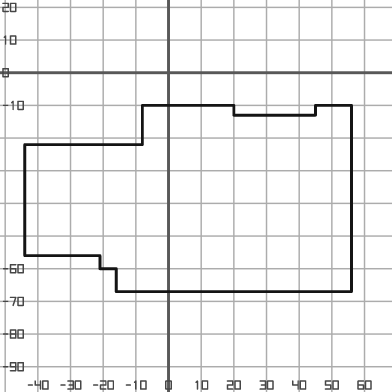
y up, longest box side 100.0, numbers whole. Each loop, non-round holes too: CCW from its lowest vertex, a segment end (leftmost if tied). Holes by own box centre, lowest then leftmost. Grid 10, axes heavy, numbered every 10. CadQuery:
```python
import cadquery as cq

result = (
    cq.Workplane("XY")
    .moveTo(-16.0, -67.0)
    .lineTo(56.0, -67.0)
    .lineTo(56.0, -10.0)
    .lineTo(45.0, -10.0)
    .lineTo(45.0, -13.0)
    .lineTo(20.0, -13.0)
    .lineTo(20.0, -10.0)
    .lineTo(-8.0, -10.0)
    .lineTo(-8.0, -22.0)
    .lineTo(-44.0, -22.0)
    .lineTo(-44.0, -56.0)
    .lineTo(-21.0, -56.0)
    .lineTo(-21.0, -60.0)
    .lineTo(-16.0, -60.0)
    .close()
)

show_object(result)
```